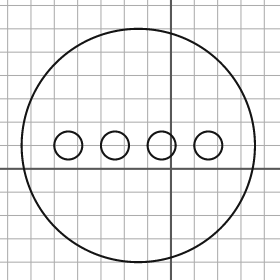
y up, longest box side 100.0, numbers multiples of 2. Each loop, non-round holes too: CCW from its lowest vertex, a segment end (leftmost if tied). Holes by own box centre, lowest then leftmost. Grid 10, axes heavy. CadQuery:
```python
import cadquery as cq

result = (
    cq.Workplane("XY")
    .moveTo(-14.0, 10.0)
    .circle(50.0)
    .moveTo(-44.0, 10.0)
    .circle(6.0)
    .moveTo(-24.0, 10.0)
    .circle(6.0)
    .moveTo(-4.0, 10.0)
    .circle(6.0)
    .moveTo(16.0, 10.0)
    .circle(6.0)
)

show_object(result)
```